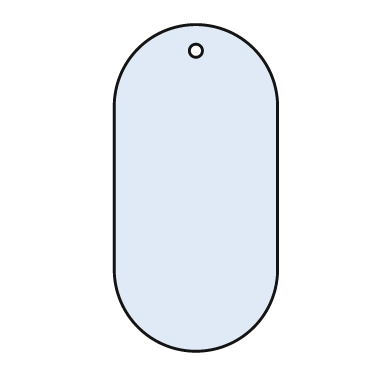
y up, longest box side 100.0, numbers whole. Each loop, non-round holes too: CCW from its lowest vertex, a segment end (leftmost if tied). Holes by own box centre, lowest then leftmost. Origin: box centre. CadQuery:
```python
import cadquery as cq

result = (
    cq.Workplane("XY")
    .moveTo(-25.0, -25.0)
    .threePointArc((0.0, -50.0), (25.0, -25.0))
    .lineTo(25.0, 25.0)
    .threePointArc((0.0, 50.0), (-25.0, 25.0))
    .close()
    .moveTo(0.0, 42.0)
    .circle(2.0)
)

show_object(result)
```